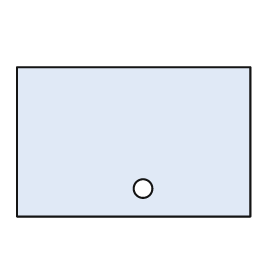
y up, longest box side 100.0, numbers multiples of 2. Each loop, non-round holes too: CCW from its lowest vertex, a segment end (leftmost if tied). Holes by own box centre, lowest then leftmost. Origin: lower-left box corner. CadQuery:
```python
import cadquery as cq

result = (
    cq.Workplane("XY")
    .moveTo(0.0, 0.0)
    .lineTo(100.0, 0.0)
    .lineTo(100.0, 64.0)
    .lineTo(0.0, 64.0)
    .close()
    .moveTo(54.0, 12.0)
    .circle(4.0)
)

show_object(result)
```